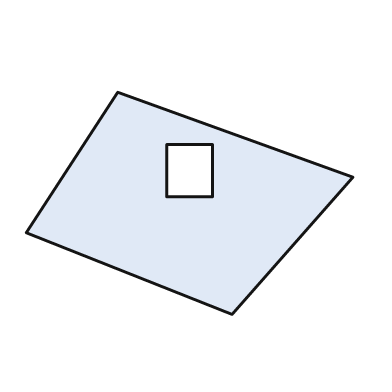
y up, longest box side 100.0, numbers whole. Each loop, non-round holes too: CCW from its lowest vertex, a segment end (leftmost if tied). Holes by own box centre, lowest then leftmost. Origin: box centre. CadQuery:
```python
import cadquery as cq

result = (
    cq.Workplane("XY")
    .moveTo(13.0, -34.0)
    .lineTo(50.0, 8.0)
    .lineTo(-22.0, 34.0)
    .lineTo(-50.0, -9.0)
    .close()
    .moveTo(-7.0, 2.0)
    .lineTo(7.0, 2.0)
    .lineTo(7.0, 18.0)
    .lineTo(-7.0, 18.0)
    .close()
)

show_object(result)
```